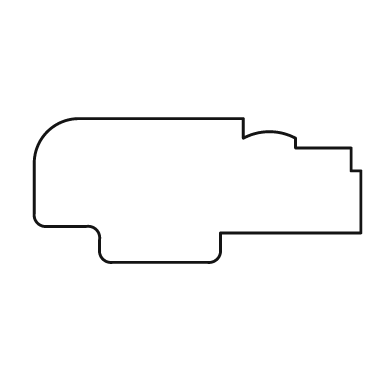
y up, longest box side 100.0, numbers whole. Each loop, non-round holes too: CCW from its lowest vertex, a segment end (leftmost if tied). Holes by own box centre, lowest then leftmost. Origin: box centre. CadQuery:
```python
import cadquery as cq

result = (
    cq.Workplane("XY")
    .moveTo(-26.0, -22.0)
    .lineTo(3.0, -22.0)
    .threePointArc((6.0, -21.0), (7.0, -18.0))
    .lineTo(7.0, -13.0)
    .lineTo(50.0, -13.0)
    .lineTo(50.0, 6.0)
    .lineTo(47.0, 6.0)
    .lineTo(47.0, 13.0)
    .lineTo(30.0, 13.0)
    .lineTo(30.0, 16.0)
    .threePointArc((22.0, 18.0), (14.0, 16.0))
    .lineTo(14.0, 22.0)
    .lineTo(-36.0, 22.0)
    .threePointArc((-46.0, 18.0), (-50.0, 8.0))
    .lineTo(-50.0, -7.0)
    .threePointArc((-49.0, -10.0), (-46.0, -11.0))
    .lineTo(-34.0, -11.0)
    .threePointArc((-31.0, -12.0), (-30.0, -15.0))
    .lineTo(-30.0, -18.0)
    .threePointArc((-29.0, -21.0), (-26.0, -22.0))
    .close()
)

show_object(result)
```